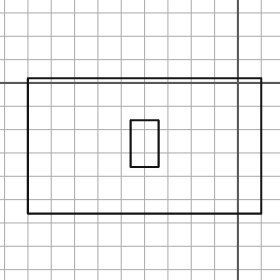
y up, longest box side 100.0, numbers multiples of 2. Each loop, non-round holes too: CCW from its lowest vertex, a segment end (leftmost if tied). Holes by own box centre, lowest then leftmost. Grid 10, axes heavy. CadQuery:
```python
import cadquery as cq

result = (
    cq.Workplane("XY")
    .moveTo(-90.0, -56.0)
    .lineTo(10.0, -56.0)
    .lineTo(10.0, 2.0)
    .lineTo(-90.0, 2.0)
    .close()
    .moveTo(-46.0, -36.0)
    .lineTo(-34.0, -36.0)
    .lineTo(-34.0, -16.0)
    .lineTo(-46.0, -16.0)
    .close()
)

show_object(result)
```